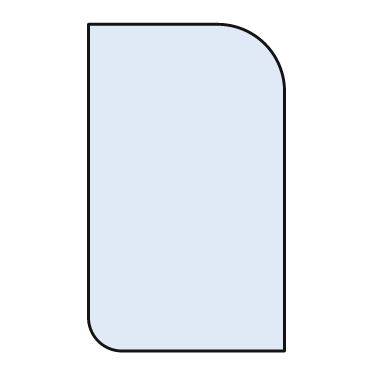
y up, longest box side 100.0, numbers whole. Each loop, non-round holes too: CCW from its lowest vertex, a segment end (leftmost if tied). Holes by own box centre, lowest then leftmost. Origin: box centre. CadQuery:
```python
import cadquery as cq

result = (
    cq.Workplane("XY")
    .moveTo(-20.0, -50.0)
    .lineTo(30.0, -50.0)
    .lineTo(30.0, 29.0)
    .threePointArc((24.0, 44.0), (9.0, 50.0))
    .lineTo(-30.0, 50.0)
    .lineTo(-30.0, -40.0)
    .threePointArc((-27.0, -47.0), (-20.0, -50.0))
    .close()
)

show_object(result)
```